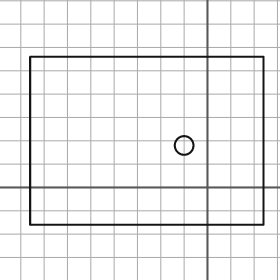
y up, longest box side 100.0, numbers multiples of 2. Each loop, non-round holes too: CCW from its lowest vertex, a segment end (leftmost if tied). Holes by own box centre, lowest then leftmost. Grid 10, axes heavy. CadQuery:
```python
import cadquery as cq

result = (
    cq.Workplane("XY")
    .moveTo(-76.0, -16.0)
    .lineTo(24.0, -16.0)
    .lineTo(24.0, 56.0)
    .lineTo(-76.0, 56.0)
    .close()
    .moveTo(-10.0, 18.0)
    .circle(4.0)
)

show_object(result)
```